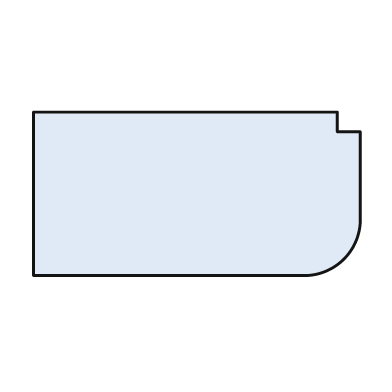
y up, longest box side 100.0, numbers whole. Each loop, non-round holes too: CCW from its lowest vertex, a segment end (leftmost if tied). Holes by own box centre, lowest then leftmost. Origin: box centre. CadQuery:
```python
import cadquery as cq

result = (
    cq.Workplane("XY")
    .moveTo(-50.0, -25.0)
    .lineTo(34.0, -25.0)
    .threePointArc((45.0, -20.0), (50.0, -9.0))
    .lineTo(50.0, 19.0)
    .lineTo(43.0, 19.0)
    .lineTo(43.0, 25.0)
    .lineTo(-50.0, 25.0)
    .close()
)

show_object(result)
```